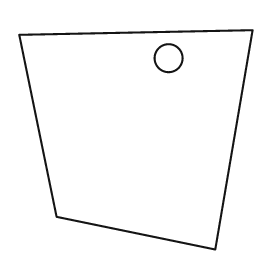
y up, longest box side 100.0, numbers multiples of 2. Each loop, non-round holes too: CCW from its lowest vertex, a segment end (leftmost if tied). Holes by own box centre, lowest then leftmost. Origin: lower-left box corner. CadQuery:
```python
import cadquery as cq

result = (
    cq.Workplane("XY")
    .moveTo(84.0, 0.0)
    .lineTo(100.0, 94.0)
    .lineTo(0.0, 92.0)
    .lineTo(16.0, 14.0)
    .close()
    .moveTo(64.0, 82.0)
    .circle(6.0)
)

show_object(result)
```